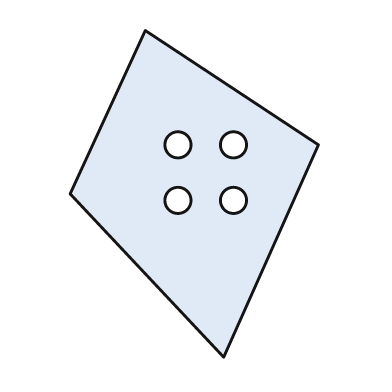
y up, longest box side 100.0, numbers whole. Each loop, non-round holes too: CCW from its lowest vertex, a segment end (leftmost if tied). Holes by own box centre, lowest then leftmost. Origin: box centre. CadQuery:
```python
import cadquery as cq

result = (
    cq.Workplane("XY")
    .moveTo(9.0, -50.0)
    .lineTo(38.0, 15.0)
    .lineTo(-15.0, 50.0)
    .lineTo(-38.0, 0.0)
    .close()
    .moveTo(-5.0, -2.0)
    .circle(4.0)
    .moveTo(12.0, -2.0)
    .circle(4.0)
    .moveTo(-5.0, 15.0)
    .circle(4.0)
    .moveTo(12.0, 15.0)
    .circle(4.0)
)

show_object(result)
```